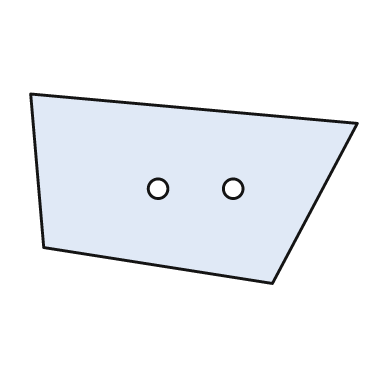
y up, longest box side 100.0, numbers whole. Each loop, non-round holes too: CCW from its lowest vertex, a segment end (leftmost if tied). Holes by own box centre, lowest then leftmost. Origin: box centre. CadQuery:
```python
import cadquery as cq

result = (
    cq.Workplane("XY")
    .moveTo(24.0, -29.0)
    .lineTo(50.0, 20.0)
    .lineTo(-50.0, 29.0)
    .lineTo(-46.0, -18.0)
    .close()
    .moveTo(-11.0, 0.0)
    .circle(3.0)
    .moveTo(12.0, 0.0)
    .circle(3.0)
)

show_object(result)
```